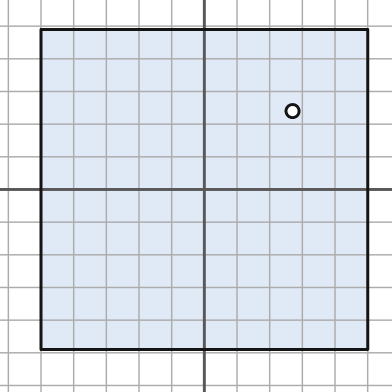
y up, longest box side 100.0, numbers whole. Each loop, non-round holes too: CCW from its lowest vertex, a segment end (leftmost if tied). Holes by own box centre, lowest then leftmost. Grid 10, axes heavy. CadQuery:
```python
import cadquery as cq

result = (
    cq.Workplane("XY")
    .moveTo(-50.0, -49.0)
    .lineTo(50.0, -49.0)
    .lineTo(50.0, 49.0)
    .lineTo(-50.0, 49.0)
    .close()
    .moveTo(27.0, 24.0)
    .circle(2.0)
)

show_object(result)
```